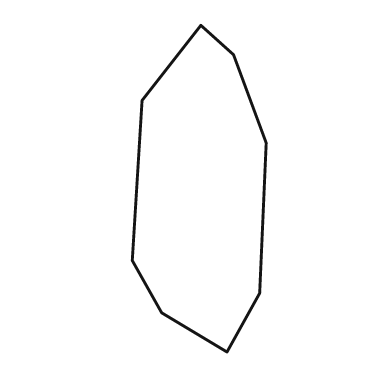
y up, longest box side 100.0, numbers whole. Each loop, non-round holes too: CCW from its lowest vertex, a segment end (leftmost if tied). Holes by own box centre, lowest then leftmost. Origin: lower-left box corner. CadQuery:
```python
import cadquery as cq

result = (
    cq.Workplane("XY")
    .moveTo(29.0, 0.0)
    .lineTo(39.0, 18.0)
    .lineTo(41.0, 64.0)
    .lineTo(31.0, 91.0)
    .lineTo(21.0, 100.0)
    .lineTo(3.0, 77.0)
    .lineTo(0.0, 28.0)
    .lineTo(9.0, 12.0)
    .close()
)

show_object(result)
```